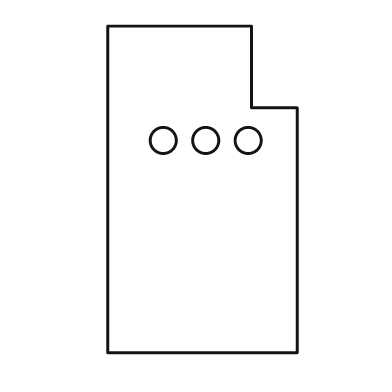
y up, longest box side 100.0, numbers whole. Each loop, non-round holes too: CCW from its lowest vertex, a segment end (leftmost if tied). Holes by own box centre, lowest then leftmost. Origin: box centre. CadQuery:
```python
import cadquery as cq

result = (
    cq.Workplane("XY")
    .moveTo(-29.0, -50.0)
    .lineTo(29.0, -50.0)
    .lineTo(29.0, 25.0)
    .lineTo(15.0, 25.0)
    .lineTo(15.0, 50.0)
    .lineTo(-29.0, 50.0)
    .close()
    .moveTo(-12.0, 15.0)
    .circle(4.0)
    .moveTo(1.0, 15.0)
    .circle(4.0)
    .moveTo(14.0, 15.0)
    .circle(4.0)
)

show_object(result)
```